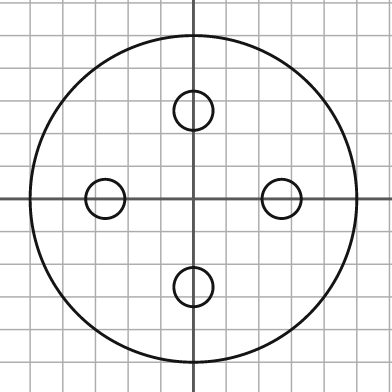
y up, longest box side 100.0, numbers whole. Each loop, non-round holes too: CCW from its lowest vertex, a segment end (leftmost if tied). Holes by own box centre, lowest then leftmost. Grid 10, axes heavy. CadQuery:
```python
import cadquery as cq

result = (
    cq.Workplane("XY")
    .moveTo(0.0, 0.0)
    .circle(50.0)
    .moveTo(0.0, -27.0)
    .circle(6.0)
    .moveTo(-27.0, 0.0)
    .circle(6.0)
    .moveTo(27.0, 0.0)
    .circle(6.0)
    .moveTo(0.0, 27.0)
    .circle(6.0)
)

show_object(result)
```